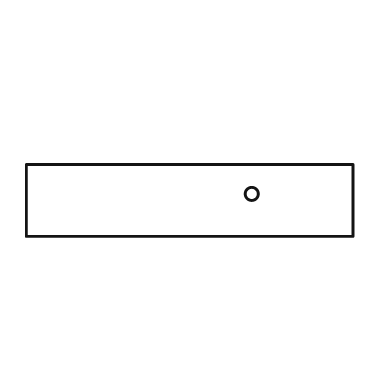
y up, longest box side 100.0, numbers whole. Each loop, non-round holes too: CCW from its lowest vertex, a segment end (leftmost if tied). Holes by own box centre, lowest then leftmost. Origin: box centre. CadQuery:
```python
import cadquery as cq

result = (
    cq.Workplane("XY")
    .moveTo(-50.0, -11.0)
    .lineTo(50.0, -11.0)
    .lineTo(50.0, 11.0)
    .lineTo(-50.0, 11.0)
    .close()
    .moveTo(19.0, 2.0)
    .circle(2.0)
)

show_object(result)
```